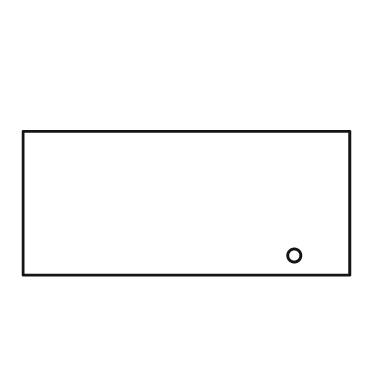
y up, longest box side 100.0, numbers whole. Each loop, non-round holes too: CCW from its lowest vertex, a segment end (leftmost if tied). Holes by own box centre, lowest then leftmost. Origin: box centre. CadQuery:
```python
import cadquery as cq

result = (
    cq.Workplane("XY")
    .moveTo(-50.0, -22.0)
    .lineTo(50.0, -22.0)
    .lineTo(50.0, 22.0)
    .lineTo(-50.0, 22.0)
    .close()
    .moveTo(33.0, -16.0)
    .circle(2.0)
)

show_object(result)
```